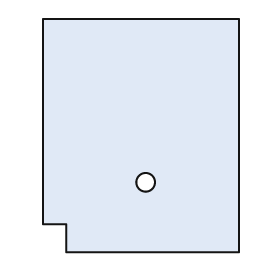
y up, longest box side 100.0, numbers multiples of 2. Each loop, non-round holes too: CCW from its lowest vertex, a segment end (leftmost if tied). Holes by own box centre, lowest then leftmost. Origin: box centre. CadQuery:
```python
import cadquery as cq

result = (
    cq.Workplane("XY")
    .moveTo(-32.0, -50.0)
    .lineTo(42.0, -50.0)
    .lineTo(42.0, 50.0)
    .lineTo(-42.0, 50.0)
    .lineTo(-42.0, -38.0)
    .lineTo(-32.0, -38.0)
    .close()
    .moveTo(2.0, -20.0)
    .circle(4.0)
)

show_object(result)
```